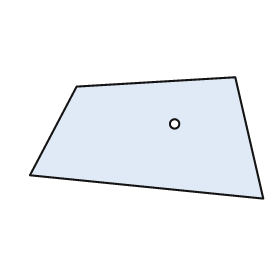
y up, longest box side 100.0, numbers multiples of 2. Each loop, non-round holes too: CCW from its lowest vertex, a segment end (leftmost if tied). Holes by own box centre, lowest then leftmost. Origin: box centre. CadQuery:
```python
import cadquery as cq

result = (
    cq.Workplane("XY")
    .moveTo(50.0, -26.0)
    .lineTo(38.0, 26.0)
    .lineTo(-30.0, 22.0)
    .lineTo(-50.0, -16.0)
    .close()
    .moveTo(12.0, 6.0)
    .circle(2.0)
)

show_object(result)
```